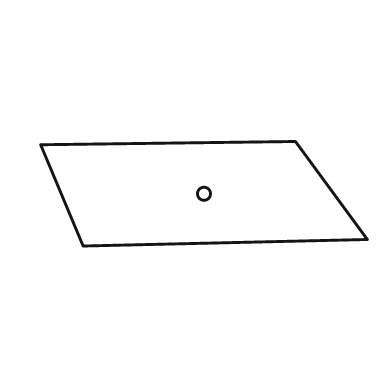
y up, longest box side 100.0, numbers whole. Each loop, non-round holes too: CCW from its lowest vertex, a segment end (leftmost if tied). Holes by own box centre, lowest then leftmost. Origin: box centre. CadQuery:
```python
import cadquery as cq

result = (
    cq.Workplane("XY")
    .moveTo(-37.0, -16.0)
    .lineTo(50.0, -14.0)
    .lineTo(28.0, 16.0)
    .lineTo(-50.0, 15.0)
    .close()
    .moveTo(0.0, 0.0)
    .circle(2.0)
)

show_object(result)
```